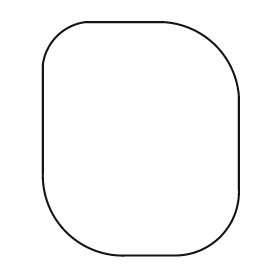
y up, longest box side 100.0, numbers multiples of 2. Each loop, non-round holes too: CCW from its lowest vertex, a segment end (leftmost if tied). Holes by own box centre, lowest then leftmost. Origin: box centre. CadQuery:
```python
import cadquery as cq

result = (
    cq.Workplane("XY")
    .moveTo(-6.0, -50.0)
    .lineTo(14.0, -50.0)
    .threePointArc((34.0, -42.0), (42.0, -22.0))
    .lineTo(42.0, 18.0)
    .threePointArc((32.0, 40.0), (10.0, 50.0))
    .lineTo(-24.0, 50.0)
    .threePointArc((-36.0, 44.0), (-42.0, 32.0))
    .lineTo(-42.0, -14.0)
    .threePointArc((-32.0, -40.0), (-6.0, -50.0))
    .close()
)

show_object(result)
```